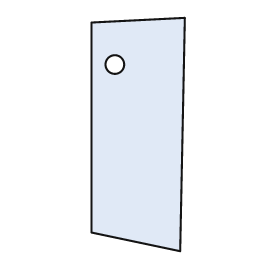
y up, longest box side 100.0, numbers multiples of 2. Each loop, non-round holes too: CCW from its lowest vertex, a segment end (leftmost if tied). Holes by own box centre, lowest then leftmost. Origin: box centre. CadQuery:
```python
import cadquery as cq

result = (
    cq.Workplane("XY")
    .moveTo(18.0, -50.0)
    .lineTo(20.0, 50.0)
    .lineTo(-20.0, 48.0)
    .lineTo(-20.0, -42.0)
    .close()
    .moveTo(-10.0, 30.0)
    .circle(4.0)
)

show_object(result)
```